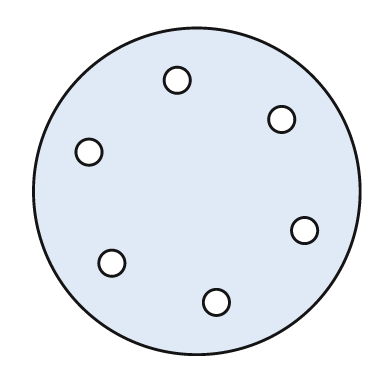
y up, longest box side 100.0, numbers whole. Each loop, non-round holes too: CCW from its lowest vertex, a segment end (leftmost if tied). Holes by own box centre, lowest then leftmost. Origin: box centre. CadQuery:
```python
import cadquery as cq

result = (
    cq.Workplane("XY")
    .moveTo(0.0, 0.0)
    .circle(50.0)
    .moveTo(6.0, -34.0)
    .circle(4.0)
    .moveTo(-26.0, -22.0)
    .circle(4.0)
    .moveTo(33.0, -12.0)
    .circle(4.0)
    .moveTo(-33.0, 12.0)
    .circle(4.0)
    .moveTo(26.0, 22.0)
    .circle(4.0)
    .moveTo(-6.0, 34.0)
    .circle(4.0)
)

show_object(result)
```